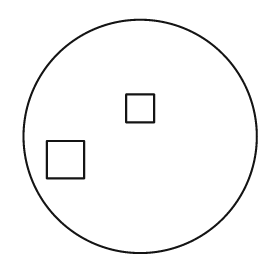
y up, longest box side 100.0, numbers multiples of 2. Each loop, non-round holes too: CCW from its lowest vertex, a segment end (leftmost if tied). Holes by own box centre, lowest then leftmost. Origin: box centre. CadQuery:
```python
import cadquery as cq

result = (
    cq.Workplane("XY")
    .moveTo(0.0, 0.0)
    .circle(50.0)
    .moveTo(-40.0, -18.0)
    .lineTo(-24.0, -18.0)
    .lineTo(-24.0, -2.0)
    .lineTo(-40.0, -2.0)
    .close()
    .moveTo(-6.0, 6.0)
    .lineTo(6.0, 6.0)
    .lineTo(6.0, 18.0)
    .lineTo(-6.0, 18.0)
    .close()
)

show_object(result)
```